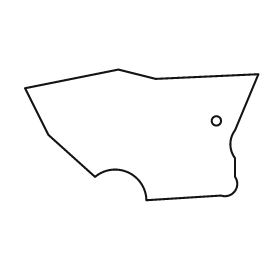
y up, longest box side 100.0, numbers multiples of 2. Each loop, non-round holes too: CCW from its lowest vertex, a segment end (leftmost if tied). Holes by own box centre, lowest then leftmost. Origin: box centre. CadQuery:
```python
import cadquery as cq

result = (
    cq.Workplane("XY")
    .moveTo(2.0, -28.0)
    .lineTo(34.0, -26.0)
    .threePointArc((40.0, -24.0), (40.0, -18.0))
    .lineTo(40.0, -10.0)
    .threePointArc((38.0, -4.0), (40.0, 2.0))
    .lineTo(50.0, 26.0)
    .lineTo(6.0, 24.0)
    .lineTo(-10.0, 28.0)
    .lineTo(-50.0, 20.0)
    .lineTo(-40.0, 0.0)
    .lineTo(-20.0, -18.0)
    .threePointArc((-6.0, -16.0), (2.0, -28.0))
    .close()
    .moveTo(32.0, 6.0)
    .circle(2.0)
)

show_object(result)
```